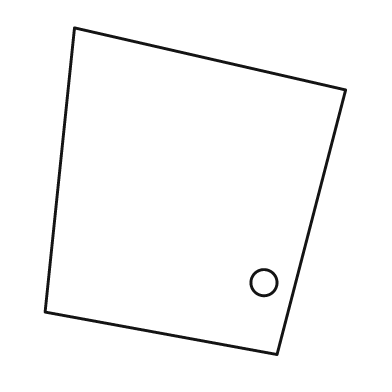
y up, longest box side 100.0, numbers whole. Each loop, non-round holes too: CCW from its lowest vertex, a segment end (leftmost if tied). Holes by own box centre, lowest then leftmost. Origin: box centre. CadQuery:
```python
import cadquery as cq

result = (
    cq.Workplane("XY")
    .moveTo(25.0, -50.0)
    .lineTo(46.0, 31.0)
    .lineTo(-37.0, 50.0)
    .lineTo(-46.0, -37.0)
    .close()
    .moveTo(21.0, -28.0)
    .circle(4.0)
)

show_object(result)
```